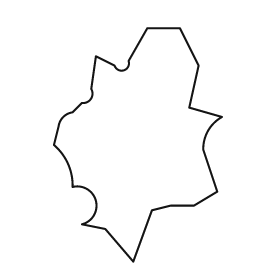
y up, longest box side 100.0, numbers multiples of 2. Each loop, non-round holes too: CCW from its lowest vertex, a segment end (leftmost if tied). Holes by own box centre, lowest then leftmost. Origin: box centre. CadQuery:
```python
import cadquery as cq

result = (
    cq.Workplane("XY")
    .moveTo(-2.0, -50.0)
    .lineTo(6.0, -28.0)
    .lineTo(14.0, -26.0)
    .lineTo(24.0, -26.0)
    .lineTo(34.0, -20.0)
    .lineTo(28.0, -2.0)
    .threePointArc((30.0, 6.0), (36.0, 12.0))
    .lineTo(22.0, 16.0)
    .lineTo(26.0, 34.0)
    .lineTo(18.0, 50.0)
    .lineTo(4.0, 50.0)
    .lineTo(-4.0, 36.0)
    .threePointArc((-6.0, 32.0), (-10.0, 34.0))
    .lineTo(-18.0, 38.0)
    .lineTo(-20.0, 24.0)
    .threePointArc((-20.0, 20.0), (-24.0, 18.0))
    .lineTo(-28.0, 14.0)
    .threePointArc((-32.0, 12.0), (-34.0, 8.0))
    .lineTo(-36.0, 0.0)
    .threePointArc((-30.0, -8.0), (-28.0, -18.0))
    .threePointArc((-18.0, -24.0), (-24.0, -34.0))
    .lineTo(-14.0, -36.0)
    .close()
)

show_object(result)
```